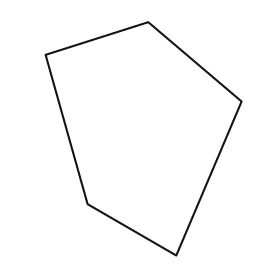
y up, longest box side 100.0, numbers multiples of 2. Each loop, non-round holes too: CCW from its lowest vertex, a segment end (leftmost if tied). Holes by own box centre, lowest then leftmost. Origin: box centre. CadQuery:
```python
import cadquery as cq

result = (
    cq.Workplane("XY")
    .moveTo(14.0, -50.0)
    .lineTo(42.0, 16.0)
    .lineTo(2.0, 50.0)
    .lineTo(-42.0, 36.0)
    .lineTo(-24.0, -28.0)
    .close()
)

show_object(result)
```